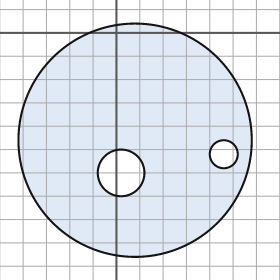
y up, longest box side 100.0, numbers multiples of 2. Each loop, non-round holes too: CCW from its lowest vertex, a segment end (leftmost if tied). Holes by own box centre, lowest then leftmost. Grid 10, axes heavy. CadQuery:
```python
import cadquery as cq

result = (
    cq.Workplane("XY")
    .moveTo(8.0, -46.0)
    .circle(50.0)
    .moveTo(2.0, -60.0)
    .circle(10.0)
    .moveTo(46.0, -52.0)
    .circle(6.0)
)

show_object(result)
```